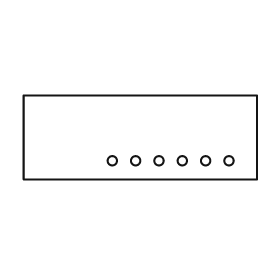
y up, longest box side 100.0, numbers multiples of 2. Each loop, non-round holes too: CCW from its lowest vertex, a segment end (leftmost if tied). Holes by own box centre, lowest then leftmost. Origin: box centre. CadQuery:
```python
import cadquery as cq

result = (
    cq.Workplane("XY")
    .moveTo(-50.0, -18.0)
    .lineTo(50.0, -18.0)
    .lineTo(50.0, 18.0)
    .lineTo(-50.0, 18.0)
    .close()
    .moveTo(-12.0, -10.0)
    .circle(2.0)
    .moveTo(-2.0, -10.0)
    .circle(2.0)
    .moveTo(8.0, -10.0)
    .circle(2.0)
    .moveTo(18.0, -10.0)
    .circle(2.0)
    .moveTo(28.0, -10.0)
    .circle(2.0)
    .moveTo(38.0, -10.0)
    .circle(2.0)
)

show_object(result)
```